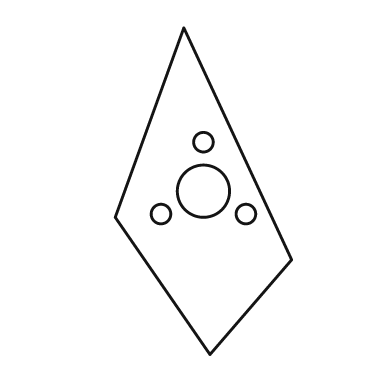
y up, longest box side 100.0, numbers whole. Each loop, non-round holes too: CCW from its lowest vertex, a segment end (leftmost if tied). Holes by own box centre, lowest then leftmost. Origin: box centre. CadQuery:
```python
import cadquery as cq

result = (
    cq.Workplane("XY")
    .moveTo(2.0, -50.0)
    .lineTo(27.0, -21.0)
    .lineTo(-6.0, 50.0)
    .lineTo(-27.0, -8.0)
    .close()
    .moveTo(-13.0, -7.0)
    .circle(3.0)
    .moveTo(13.0, -7.0)
    .circle(3.0)
    .moveTo(0.0, 0.0)
    .circle(8.0)
    .moveTo(0.0, 15.0)
    .circle(3.0)
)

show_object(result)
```